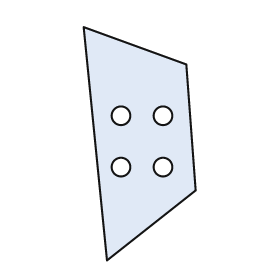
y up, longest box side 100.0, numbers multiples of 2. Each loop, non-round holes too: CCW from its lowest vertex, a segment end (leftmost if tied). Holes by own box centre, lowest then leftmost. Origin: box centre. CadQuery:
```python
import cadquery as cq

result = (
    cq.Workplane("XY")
    .moveTo(-14.0, -50.0)
    .lineTo(24.0, -20.0)
    .lineTo(20.0, 34.0)
    .lineTo(-24.0, 50.0)
    .close()
    .moveTo(-8.0, -10.0)
    .circle(4.0)
    .moveTo(10.0, -10.0)
    .circle(4.0)
    .moveTo(-8.0, 12.0)
    .circle(4.0)
    .moveTo(10.0, 12.0)
    .circle(4.0)
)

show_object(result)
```